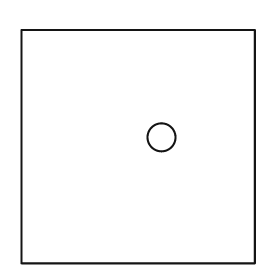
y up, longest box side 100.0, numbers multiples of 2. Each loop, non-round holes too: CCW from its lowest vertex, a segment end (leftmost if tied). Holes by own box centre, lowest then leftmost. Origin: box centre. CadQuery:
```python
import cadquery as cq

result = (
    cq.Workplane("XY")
    .moveTo(-50.0, -50.0)
    .lineTo(50.0, -50.0)
    .lineTo(50.0, 50.0)
    .lineTo(-50.0, 50.0)
    .close()
    .moveTo(10.0, 4.0)
    .circle(6.0)
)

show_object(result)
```